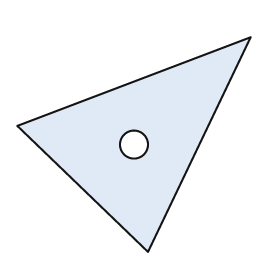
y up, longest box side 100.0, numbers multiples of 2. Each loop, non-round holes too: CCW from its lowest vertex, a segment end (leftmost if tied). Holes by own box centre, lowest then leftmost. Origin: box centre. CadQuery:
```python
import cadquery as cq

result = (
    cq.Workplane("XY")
    .moveTo(6.0, -46.0)
    .lineTo(50.0, 46.0)
    .lineTo(-50.0, 8.0)
    .close()
    .moveTo(0.0, 0.0)
    .circle(6.0)
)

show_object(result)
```